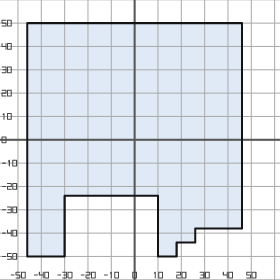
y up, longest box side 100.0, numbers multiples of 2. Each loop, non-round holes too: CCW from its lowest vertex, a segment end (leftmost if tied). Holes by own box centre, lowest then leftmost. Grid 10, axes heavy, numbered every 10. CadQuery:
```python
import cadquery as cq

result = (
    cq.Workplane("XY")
    .moveTo(-46.0, -50.0)
    .lineTo(-30.0, -50.0)
    .lineTo(-30.0, -24.0)
    .lineTo(10.0, -24.0)
    .lineTo(10.0, -50.0)
    .lineTo(18.0, -50.0)
    .lineTo(18.0, -44.0)
    .lineTo(26.0, -44.0)
    .lineTo(26.0, -38.0)
    .lineTo(46.0, -38.0)
    .lineTo(46.0, 50.0)
    .lineTo(-46.0, 50.0)
    .close()
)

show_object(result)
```